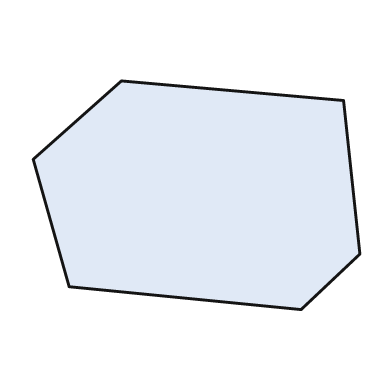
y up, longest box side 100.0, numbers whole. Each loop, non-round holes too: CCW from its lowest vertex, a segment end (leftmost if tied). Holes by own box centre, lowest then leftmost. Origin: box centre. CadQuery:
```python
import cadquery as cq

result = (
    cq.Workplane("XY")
    .moveTo(32.0, -35.0)
    .lineTo(50.0, -18.0)
    .lineTo(45.0, 29.0)
    .lineTo(-23.0, 35.0)
    .lineTo(-50.0, 11.0)
    .lineTo(-39.0, -28.0)
    .close()
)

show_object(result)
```